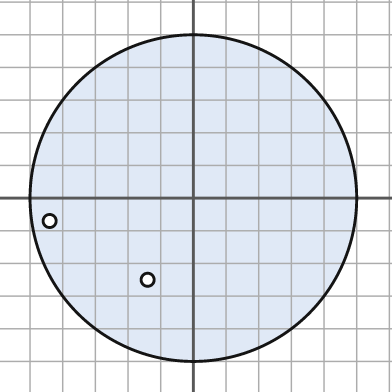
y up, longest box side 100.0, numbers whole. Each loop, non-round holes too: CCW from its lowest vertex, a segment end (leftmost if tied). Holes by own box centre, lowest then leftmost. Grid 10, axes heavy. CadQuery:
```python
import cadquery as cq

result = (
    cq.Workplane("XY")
    .moveTo(0.0, 0.0)
    .circle(50.0)
    .moveTo(-14.0, -25.0)
    .circle(2.0)
    .moveTo(-44.0, -7.0)
    .circle(2.0)
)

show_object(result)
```